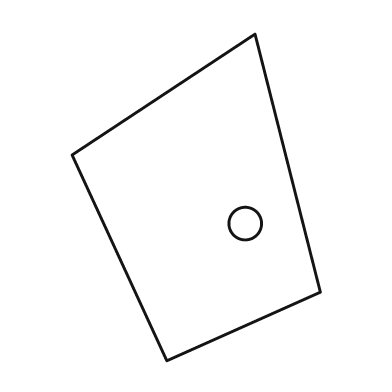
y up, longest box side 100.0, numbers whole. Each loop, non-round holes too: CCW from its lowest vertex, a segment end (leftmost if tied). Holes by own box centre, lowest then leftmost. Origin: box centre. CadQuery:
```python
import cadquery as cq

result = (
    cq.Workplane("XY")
    .moveTo(-9.0, -50.0)
    .lineTo(38.0, -29.0)
    .lineTo(18.0, 50.0)
    .lineTo(-38.0, 13.0)
    .close()
    .moveTo(15.0, -8.0)
    .circle(5.0)
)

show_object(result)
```